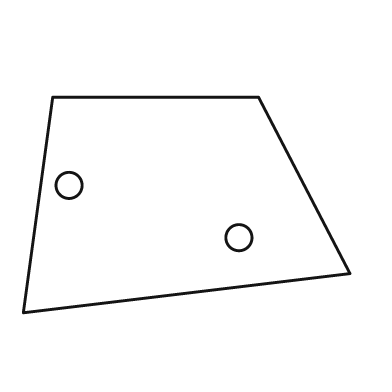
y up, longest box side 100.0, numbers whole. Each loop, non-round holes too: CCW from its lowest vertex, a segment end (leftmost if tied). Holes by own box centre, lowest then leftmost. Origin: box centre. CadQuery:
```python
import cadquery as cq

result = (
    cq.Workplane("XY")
    .moveTo(-50.0, -33.0)
    .lineTo(50.0, -21.0)
    .lineTo(22.0, 33.0)
    .lineTo(-41.0, 33.0)
    .close()
    .moveTo(16.0, -10.0)
    .circle(4.0)
    .moveTo(-36.0, 6.0)
    .circle(4.0)
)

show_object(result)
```